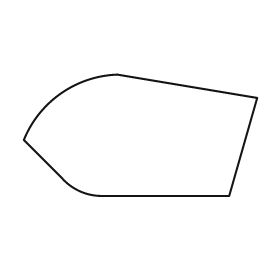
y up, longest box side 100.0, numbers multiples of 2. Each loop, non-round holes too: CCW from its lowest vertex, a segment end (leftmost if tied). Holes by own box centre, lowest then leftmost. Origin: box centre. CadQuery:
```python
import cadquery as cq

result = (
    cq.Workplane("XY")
    .moveTo(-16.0, -26.0)
    .lineTo(38.0, -26.0)
    .lineTo(50.0, 16.0)
    .lineTo(-10.0, 26.0)
    .threePointArc((-34.0, 18.0), (-50.0, -2.0))
    .lineTo(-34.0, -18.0)
    .threePointArc((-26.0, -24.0), (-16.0, -26.0))
    .close()
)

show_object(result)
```